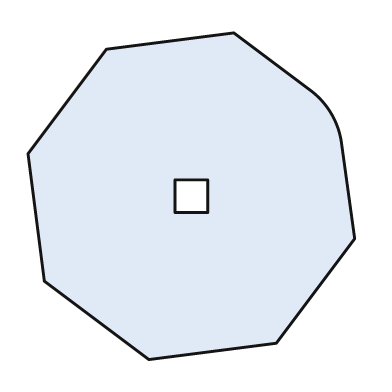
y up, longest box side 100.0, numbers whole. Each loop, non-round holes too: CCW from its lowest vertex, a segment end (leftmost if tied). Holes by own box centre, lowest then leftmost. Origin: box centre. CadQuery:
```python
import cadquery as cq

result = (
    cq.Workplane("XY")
    .moveTo(-13.0, -50.0)
    .lineTo(26.0, -45.0)
    .lineTo(50.0, -13.0)
    .lineTo(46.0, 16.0)
    .threePointArc((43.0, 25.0), (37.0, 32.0))
    .lineTo(13.0, 50.0)
    .lineTo(-26.0, 45.0)
    .lineTo(-50.0, 13.0)
    .lineTo(-45.0, -26.0)
    .close()
    .moveTo(-5.0, -5.0)
    .lineTo(5.0, -5.0)
    .lineTo(5.0, 5.0)
    .lineTo(-5.0, 5.0)
    .close()
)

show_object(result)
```